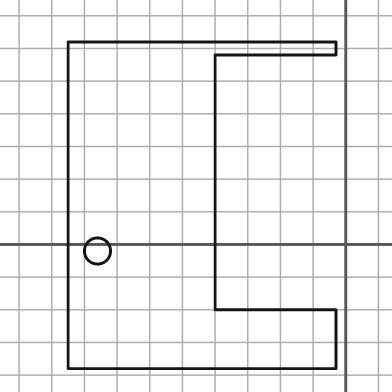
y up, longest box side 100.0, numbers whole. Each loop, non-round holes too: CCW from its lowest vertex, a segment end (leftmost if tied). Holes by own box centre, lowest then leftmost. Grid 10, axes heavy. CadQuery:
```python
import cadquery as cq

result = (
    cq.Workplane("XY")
    .moveTo(-85.0, -38.0)
    .lineTo(-3.0, -38.0)
    .lineTo(-3.0, -20.0)
    .lineTo(-40.0, -20.0)
    .lineTo(-40.0, 58.0)
    .lineTo(-3.0, 58.0)
    .lineTo(-3.0, 62.0)
    .lineTo(-85.0, 62.0)
    .close()
    .moveTo(-76.0, -2.0)
    .circle(4.0)
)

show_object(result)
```